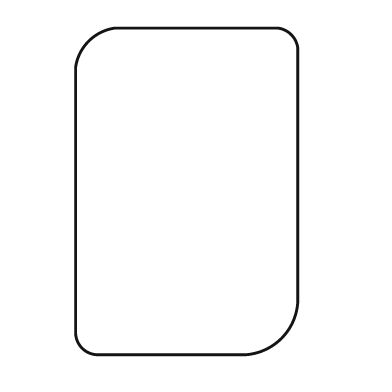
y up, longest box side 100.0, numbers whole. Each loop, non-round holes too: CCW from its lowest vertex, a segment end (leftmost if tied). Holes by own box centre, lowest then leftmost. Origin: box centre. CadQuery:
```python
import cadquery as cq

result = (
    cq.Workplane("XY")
    .moveTo(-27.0, -50.0)
    .lineTo(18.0, -50.0)
    .threePointArc((29.0, -45.0), (34.0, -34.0))
    .lineTo(34.0, 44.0)
    .threePointArc((32.0, 48.0), (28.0, 50.0))
    .lineTo(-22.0, 50.0)
    .threePointArc((-30.0, 46.0), (-34.0, 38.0))
    .lineTo(-34.0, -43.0)
    .threePointArc((-32.0, -48.0), (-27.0, -50.0))
    .close()
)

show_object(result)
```